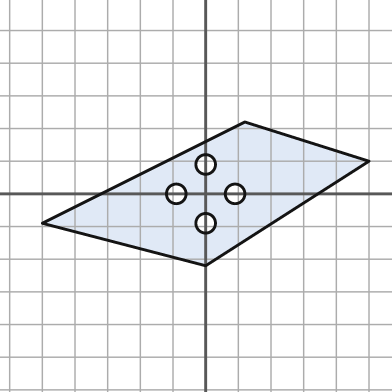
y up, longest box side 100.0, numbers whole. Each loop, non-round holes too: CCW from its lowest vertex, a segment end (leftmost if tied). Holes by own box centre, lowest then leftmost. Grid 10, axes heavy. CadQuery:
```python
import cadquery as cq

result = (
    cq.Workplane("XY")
    .moveTo(0.0, -22.0)
    .lineTo(50.0, 10.0)
    .lineTo(12.0, 22.0)
    .lineTo(-50.0, -9.0)
    .close()
    .moveTo(0.0, -9.0)
    .circle(3.0)
    .moveTo(-9.0, 0.0)
    .circle(3.0)
    .moveTo(9.0, 0.0)
    .circle(3.0)
    .moveTo(0.0, 9.0)
    .circle(3.0)
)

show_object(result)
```